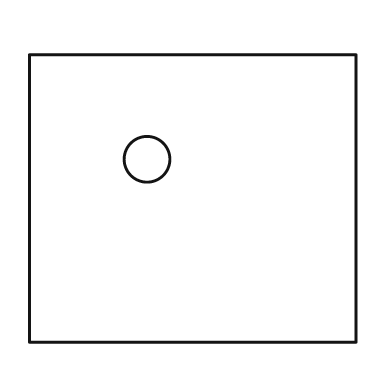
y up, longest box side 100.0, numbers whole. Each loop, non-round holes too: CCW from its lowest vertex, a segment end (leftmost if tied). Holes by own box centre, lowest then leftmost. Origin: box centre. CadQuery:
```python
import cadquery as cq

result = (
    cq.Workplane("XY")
    .moveTo(-50.0, -44.0)
    .lineTo(50.0, -44.0)
    .lineTo(50.0, 44.0)
    .lineTo(-50.0, 44.0)
    .close()
    .moveTo(-14.0, 12.0)
    .circle(7.0)
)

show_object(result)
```